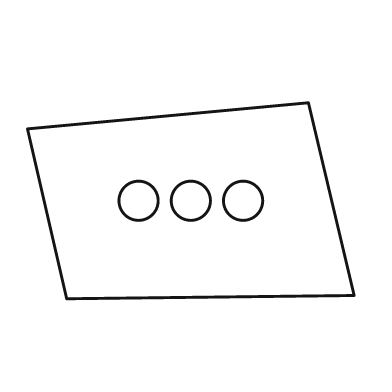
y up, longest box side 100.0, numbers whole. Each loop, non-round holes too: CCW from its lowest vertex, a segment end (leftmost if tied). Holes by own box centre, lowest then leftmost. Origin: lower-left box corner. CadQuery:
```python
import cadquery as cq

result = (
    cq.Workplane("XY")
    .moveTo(12.0, 0.0)
    .lineTo(100.0, 1.0)
    .lineTo(86.0, 60.0)
    .lineTo(0.0, 52.0)
    .close()
    .moveTo(34.0, 30.0)
    .circle(6.0)
    .moveTo(50.0, 30.0)
    .circle(6.0)
    .moveTo(66.0, 30.0)
    .circle(6.0)
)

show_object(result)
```